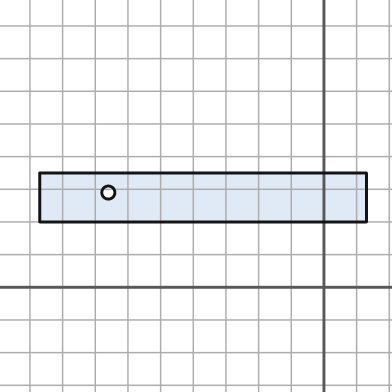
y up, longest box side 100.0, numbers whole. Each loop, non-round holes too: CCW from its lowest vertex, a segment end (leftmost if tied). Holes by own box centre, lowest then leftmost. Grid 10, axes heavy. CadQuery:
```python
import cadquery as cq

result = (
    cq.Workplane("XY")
    .moveTo(-87.0, 20.0)
    .lineTo(13.0, 20.0)
    .lineTo(13.0, 35.0)
    .lineTo(-87.0, 35.0)
    .close()
    .moveTo(-66.0, 29.0)
    .circle(2.0)
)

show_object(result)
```